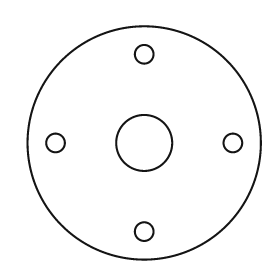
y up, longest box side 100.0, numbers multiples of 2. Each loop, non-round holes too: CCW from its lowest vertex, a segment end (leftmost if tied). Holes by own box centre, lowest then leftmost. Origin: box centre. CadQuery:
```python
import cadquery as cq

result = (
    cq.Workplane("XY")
    .moveTo(0.0, 0.0)
    .circle(50.0)
    .moveTo(0.0, -38.0)
    .circle(4.0)
    .moveTo(-38.0, 0.0)
    .circle(4.0)
    .moveTo(0.0, 0.0)
    .circle(12.0)
    .moveTo(38.0, 0.0)
    .circle(4.0)
    .moveTo(0.0, 38.0)
    .circle(4.0)
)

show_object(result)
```